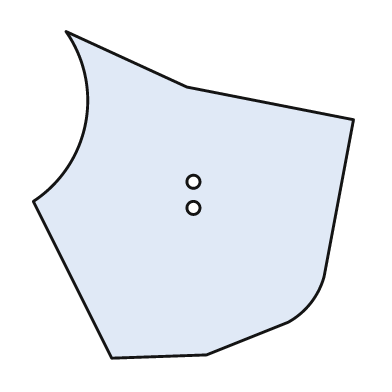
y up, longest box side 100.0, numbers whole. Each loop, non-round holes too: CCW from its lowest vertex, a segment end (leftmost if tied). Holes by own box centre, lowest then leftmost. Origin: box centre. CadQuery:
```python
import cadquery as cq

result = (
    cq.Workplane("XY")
    .moveTo(-25.0, -50.0)
    .lineTo(4.0, -49.0)
    .lineTo(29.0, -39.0)
    .threePointArc((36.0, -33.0), (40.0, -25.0))
    .lineTo(49.0, 23.0)
    .lineTo(-2.0, 33.0)
    .lineTo(-39.0, 50.0)
    .threePointArc((-33.0, 22.0), (-49.0, -2.0))
    .close()
    .moveTo(0.0, -4.0)
    .circle(2.0)
    .moveTo(0.0, 4.0)
    .circle(2.0)
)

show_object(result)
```